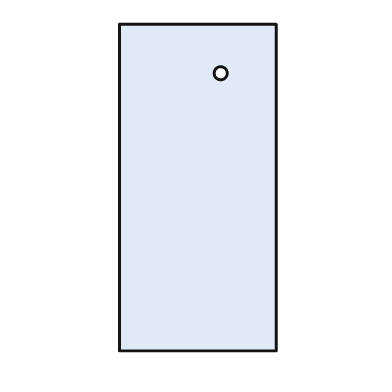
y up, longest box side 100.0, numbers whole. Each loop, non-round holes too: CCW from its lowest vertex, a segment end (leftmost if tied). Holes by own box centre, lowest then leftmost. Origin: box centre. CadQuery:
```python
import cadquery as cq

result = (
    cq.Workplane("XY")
    .moveTo(-24.0, -50.0)
    .lineTo(24.0, -50.0)
    .lineTo(24.0, 50.0)
    .lineTo(-24.0, 50.0)
    .close()
    .moveTo(7.0, 35.0)
    .circle(2.0)
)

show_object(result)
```